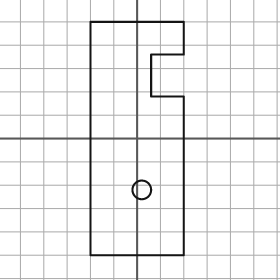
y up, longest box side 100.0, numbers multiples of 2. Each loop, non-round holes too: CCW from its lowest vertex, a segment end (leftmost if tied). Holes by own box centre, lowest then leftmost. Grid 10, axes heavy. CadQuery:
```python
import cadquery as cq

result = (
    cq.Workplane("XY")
    .moveTo(-20.0, -50.0)
    .lineTo(20.0, -50.0)
    .lineTo(20.0, 18.0)
    .lineTo(6.0, 18.0)
    .lineTo(6.0, 36.0)
    .lineTo(20.0, 36.0)
    .lineTo(20.0, 50.0)
    .lineTo(-20.0, 50.0)
    .close()
    .moveTo(2.0, -22.0)
    .circle(4.0)
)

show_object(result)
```